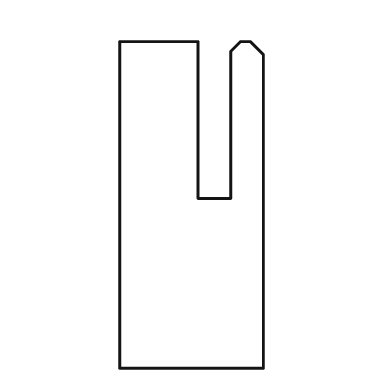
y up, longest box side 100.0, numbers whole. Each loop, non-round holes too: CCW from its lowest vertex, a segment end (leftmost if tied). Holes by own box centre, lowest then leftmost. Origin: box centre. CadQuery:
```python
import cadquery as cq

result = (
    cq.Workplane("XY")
    .moveTo(-22.0, -50.0)
    .lineTo(22.0, -50.0)
    .lineTo(22.0, 46.0)
    .lineTo(18.0, 50.0)
    .lineTo(15.0, 50.0)
    .lineTo(12.0, 47.0)
    .lineTo(12.0, 2.0)
    .lineTo(2.0, 2.0)
    .lineTo(2.0, 50.0)
    .lineTo(-22.0, 50.0)
    .close()
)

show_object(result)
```